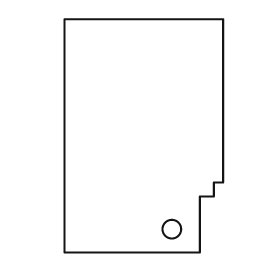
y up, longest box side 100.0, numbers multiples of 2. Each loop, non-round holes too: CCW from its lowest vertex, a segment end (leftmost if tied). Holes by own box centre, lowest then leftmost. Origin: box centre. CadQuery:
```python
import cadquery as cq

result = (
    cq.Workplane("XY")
    .moveTo(-34.0, -50.0)
    .lineTo(24.0, -50.0)
    .lineTo(24.0, -26.0)
    .lineTo(30.0, -26.0)
    .lineTo(30.0, -20.0)
    .lineTo(34.0, -20.0)
    .lineTo(34.0, 50.0)
    .lineTo(-34.0, 50.0)
    .close()
    .moveTo(12.0, -40.0)
    .circle(4.0)
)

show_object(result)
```